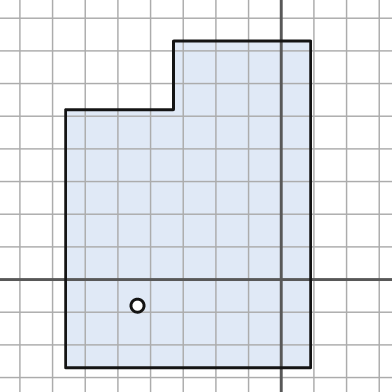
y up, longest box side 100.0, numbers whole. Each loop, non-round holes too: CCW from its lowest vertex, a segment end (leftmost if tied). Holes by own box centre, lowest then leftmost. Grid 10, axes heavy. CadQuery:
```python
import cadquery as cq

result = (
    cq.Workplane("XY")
    .moveTo(-66.0, -27.0)
    .lineTo(9.0, -27.0)
    .lineTo(9.0, 73.0)
    .lineTo(-33.0, 73.0)
    .lineTo(-33.0, 52.0)
    .lineTo(-66.0, 52.0)
    .close()
    .moveTo(-44.0, -8.0)
    .circle(2.0)
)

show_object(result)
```